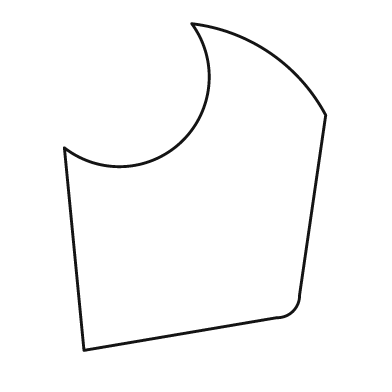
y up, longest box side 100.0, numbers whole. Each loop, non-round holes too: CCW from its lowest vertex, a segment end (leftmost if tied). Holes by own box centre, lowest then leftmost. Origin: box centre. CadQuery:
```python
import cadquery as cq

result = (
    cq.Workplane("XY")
    .moveTo(-34.0, -50.0)
    .lineTo(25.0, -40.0)
    .threePointArc((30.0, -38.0), (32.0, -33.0))
    .lineTo(40.0, 22.0)
    .threePointArc((23.0, 41.0), (-1.0, 50.0))
    .threePointArc((-4.0, 14.0), (-40.0, 12.0))
    .close()
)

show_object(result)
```